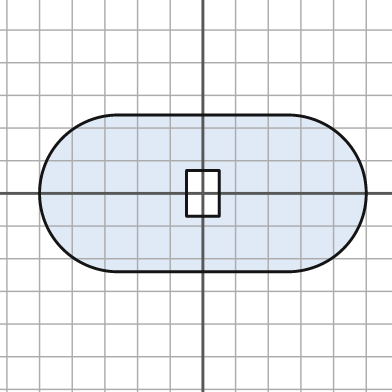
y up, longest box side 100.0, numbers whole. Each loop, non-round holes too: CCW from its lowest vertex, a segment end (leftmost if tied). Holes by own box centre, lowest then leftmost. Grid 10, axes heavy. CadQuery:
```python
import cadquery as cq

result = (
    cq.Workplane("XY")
    .moveTo(-26.0, -24.0)
    .lineTo(26.0, -24.0)
    .threePointArc((50.0, 0.0), (26.0, 24.0))
    .lineTo(-26.0, 24.0)
    .threePointArc((-50.0, 0.0), (-26.0, -24.0))
    .close()
    .moveTo(-5.0, -7.0)
    .lineTo(5.0, -7.0)
    .lineTo(5.0, 7.0)
    .lineTo(-5.0, 7.0)
    .close()
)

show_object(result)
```